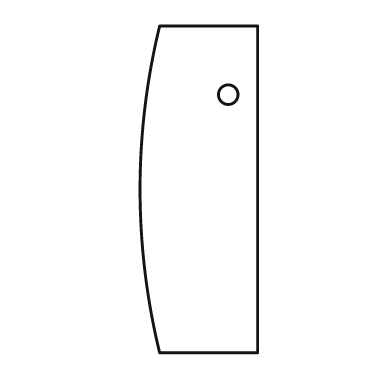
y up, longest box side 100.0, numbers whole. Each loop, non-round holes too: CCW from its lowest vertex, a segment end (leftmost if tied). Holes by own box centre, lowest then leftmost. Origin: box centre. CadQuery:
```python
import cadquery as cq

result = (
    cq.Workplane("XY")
    .moveTo(-12.0, -50.0)
    .lineTo(18.0, -50.0)
    .lineTo(18.0, 50.0)
    .lineTo(-12.0, 50.0)
    .threePointArc((-18.0, 0.0), (-12.0, -50.0))
    .close()
    .moveTo(9.0, 29.0)
    .circle(3.0)
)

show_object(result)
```